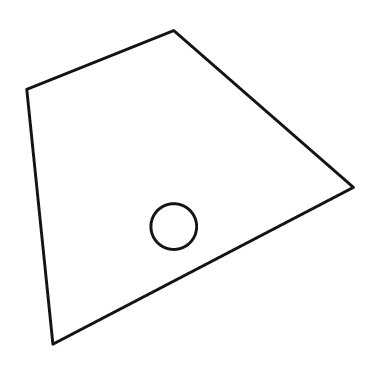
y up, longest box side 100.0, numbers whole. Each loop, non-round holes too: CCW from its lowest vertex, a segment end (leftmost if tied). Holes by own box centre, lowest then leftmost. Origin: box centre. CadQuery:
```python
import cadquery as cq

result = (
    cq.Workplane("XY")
    .moveTo(-42.0, -48.0)
    .lineTo(50.0, 0.0)
    .lineTo(-5.0, 48.0)
    .lineTo(-50.0, 30.0)
    .close()
    .moveTo(-5.0, -12.0)
    .circle(7.0)
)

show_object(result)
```